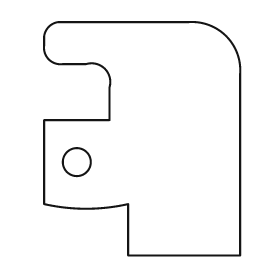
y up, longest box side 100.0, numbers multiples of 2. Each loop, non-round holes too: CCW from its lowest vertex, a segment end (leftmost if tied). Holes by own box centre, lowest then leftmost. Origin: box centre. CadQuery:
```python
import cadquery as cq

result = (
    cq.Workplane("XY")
    .moveTo(-6.0, -50.0)
    .lineTo(42.0, -50.0)
    .lineTo(42.0, 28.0)
    .threePointArc((36.0, 44.0), (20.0, 50.0))
    .lineTo(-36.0, 50.0)
    .threePointArc((-40.0, 48.0), (-42.0, 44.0))
    .lineTo(-42.0, 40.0)
    .threePointArc((-40.0, 34.0), (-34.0, 32.0))
    .lineTo(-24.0, 32.0)
    .threePointArc((-16.0, 30.0), (-14.0, 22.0))
    .lineTo(-14.0, 8.0)
    .lineTo(-42.0, 8.0)
    .lineTo(-42.0, -28.0)
    .threePointArc((-24.0, -30.0), (-6.0, -28.0))
    .close()
    .moveTo(-28.0, -10.0)
    .circle(6.0)
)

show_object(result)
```